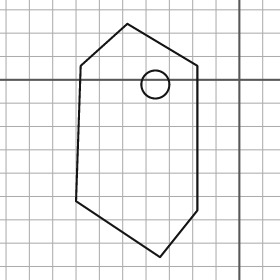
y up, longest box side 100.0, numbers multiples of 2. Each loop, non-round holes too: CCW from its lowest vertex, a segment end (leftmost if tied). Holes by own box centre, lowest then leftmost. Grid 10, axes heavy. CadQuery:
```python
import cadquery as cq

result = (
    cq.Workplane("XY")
    .moveTo(-34.0, -76.0)
    .lineTo(-18.0, -56.0)
    .lineTo(-18.0, 6.0)
    .lineTo(-48.0, 24.0)
    .lineTo(-68.0, 6.0)
    .lineTo(-70.0, -52.0)
    .close()
    .moveTo(-36.0, -2.0)
    .circle(6.0)
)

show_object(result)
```